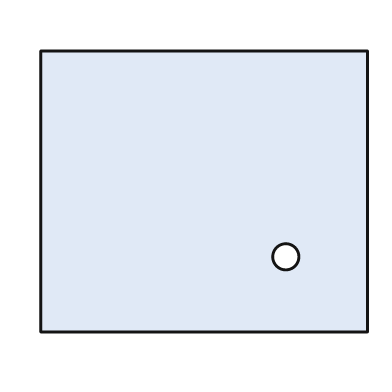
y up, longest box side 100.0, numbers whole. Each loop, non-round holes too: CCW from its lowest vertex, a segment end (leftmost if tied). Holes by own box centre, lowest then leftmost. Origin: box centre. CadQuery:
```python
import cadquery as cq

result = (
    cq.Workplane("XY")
    .moveTo(-50.0, -43.0)
    .lineTo(50.0, -43.0)
    .lineTo(50.0, 43.0)
    .lineTo(-50.0, 43.0)
    .close()
    .moveTo(25.0, -20.0)
    .circle(4.0)
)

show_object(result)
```